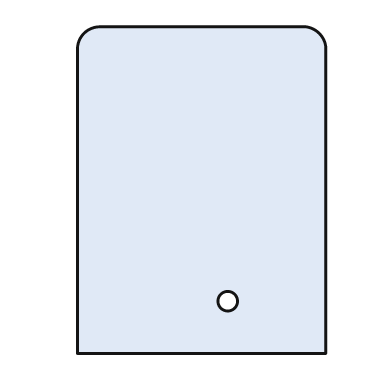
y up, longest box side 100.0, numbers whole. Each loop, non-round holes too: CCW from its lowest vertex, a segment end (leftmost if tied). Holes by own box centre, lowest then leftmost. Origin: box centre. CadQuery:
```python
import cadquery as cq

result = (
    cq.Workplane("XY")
    .moveTo(-38.0, -50.0)
    .lineTo(38.0, -50.0)
    .lineTo(38.0, 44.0)
    .threePointArc((36.0, 48.0), (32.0, 50.0))
    .lineTo(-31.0, 50.0)
    .threePointArc((-36.0, 48.0), (-38.0, 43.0))
    .close()
    .moveTo(8.0, -34.0)
    .circle(3.0)
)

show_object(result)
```